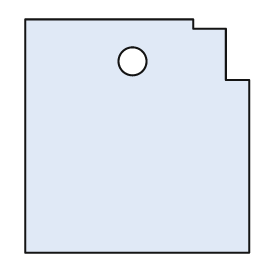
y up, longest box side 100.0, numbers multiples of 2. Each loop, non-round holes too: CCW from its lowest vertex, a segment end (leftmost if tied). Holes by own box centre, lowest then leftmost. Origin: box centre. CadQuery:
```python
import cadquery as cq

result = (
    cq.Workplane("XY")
    .moveTo(-48.0, -50.0)
    .lineTo(48.0, -50.0)
    .lineTo(48.0, 24.0)
    .lineTo(38.0, 24.0)
    .lineTo(38.0, 46.0)
    .lineTo(24.0, 46.0)
    .lineTo(24.0, 50.0)
    .lineTo(-48.0, 50.0)
    .close()
    .moveTo(-2.0, 32.0)
    .circle(6.0)
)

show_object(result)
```